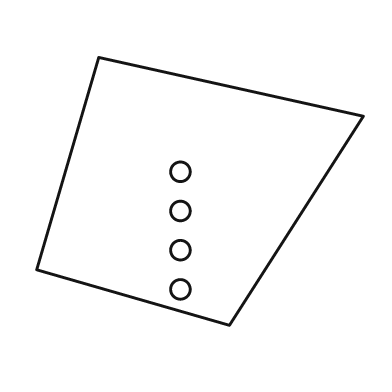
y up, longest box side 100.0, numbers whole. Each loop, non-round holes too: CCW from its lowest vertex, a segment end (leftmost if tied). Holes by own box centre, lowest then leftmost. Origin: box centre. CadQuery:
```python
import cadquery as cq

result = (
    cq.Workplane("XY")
    .moveTo(9.0, -41.0)
    .lineTo(50.0, 23.0)
    .lineTo(-31.0, 41.0)
    .lineTo(-50.0, -24.0)
    .close()
    .moveTo(-6.0, -30.0)
    .circle(3.0)
    .moveTo(-6.0, -18.0)
    .circle(3.0)
    .moveTo(-6.0, -6.0)
    .circle(3.0)
    .moveTo(-6.0, 6.0)
    .circle(3.0)
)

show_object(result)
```